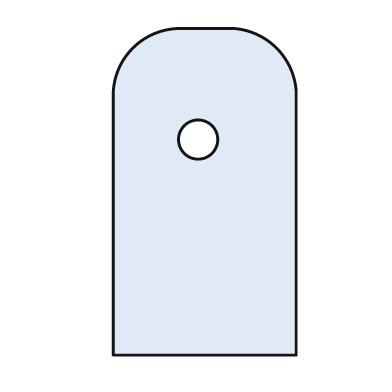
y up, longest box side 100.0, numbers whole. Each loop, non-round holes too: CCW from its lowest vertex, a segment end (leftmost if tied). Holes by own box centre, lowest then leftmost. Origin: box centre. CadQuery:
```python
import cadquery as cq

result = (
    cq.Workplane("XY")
    .moveTo(-28.0, -50.0)
    .lineTo(28.0, -50.0)
    .lineTo(28.0, 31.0)
    .threePointArc((22.0, 44.0), (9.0, 50.0))
    .lineTo(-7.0, 50.0)
    .threePointArc((-22.0, 44.0), (-28.0, 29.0))
    .close()
    .moveTo(-2.0, 16.0)
    .circle(6.0)
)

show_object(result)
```